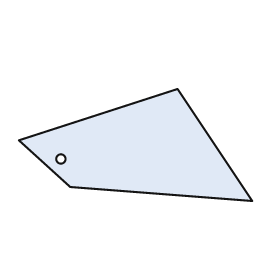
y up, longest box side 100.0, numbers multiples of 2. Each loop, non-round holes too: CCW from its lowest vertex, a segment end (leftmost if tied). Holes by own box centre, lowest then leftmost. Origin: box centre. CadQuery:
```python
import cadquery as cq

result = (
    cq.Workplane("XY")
    .moveTo(50.0, -24.0)
    .lineTo(18.0, 24.0)
    .lineTo(-50.0, 2.0)
    .lineTo(-28.0, -18.0)
    .close()
    .moveTo(-32.0, -6.0)
    .circle(2.0)
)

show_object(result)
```